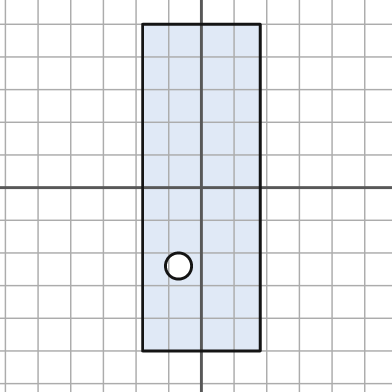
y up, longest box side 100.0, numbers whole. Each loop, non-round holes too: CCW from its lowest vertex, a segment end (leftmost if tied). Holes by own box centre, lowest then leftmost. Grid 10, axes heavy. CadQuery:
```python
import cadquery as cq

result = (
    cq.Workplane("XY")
    .moveTo(-18.0, -50.0)
    .lineTo(18.0, -50.0)
    .lineTo(18.0, 50.0)
    .lineTo(-18.0, 50.0)
    .close()
    .moveTo(-7.0, -24.0)
    .circle(4.0)
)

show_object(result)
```